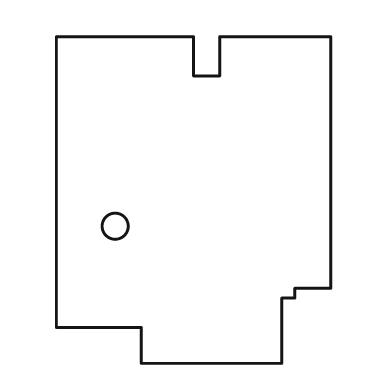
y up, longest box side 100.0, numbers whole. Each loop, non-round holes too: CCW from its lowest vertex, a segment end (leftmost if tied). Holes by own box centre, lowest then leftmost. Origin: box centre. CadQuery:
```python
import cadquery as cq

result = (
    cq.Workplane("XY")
    .moveTo(-16.0, -50.0)
    .lineTo(27.0, -50.0)
    .lineTo(27.0, -30.0)
    .lineTo(31.0, -30.0)
    .lineTo(31.0, -27.0)
    .lineTo(42.0, -27.0)
    .lineTo(42.0, 50.0)
    .lineTo(8.0, 50.0)
    .lineTo(8.0, 38.0)
    .lineTo(0.0, 38.0)
    .lineTo(0.0, 50.0)
    .lineTo(-42.0, 50.0)
    .lineTo(-42.0, -39.0)
    .lineTo(-16.0, -39.0)
    .close()
    .moveTo(-24.0, -8.0)
    .circle(4.0)
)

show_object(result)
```